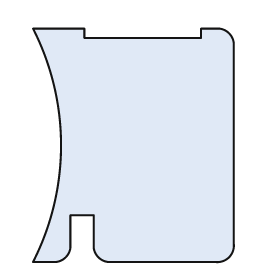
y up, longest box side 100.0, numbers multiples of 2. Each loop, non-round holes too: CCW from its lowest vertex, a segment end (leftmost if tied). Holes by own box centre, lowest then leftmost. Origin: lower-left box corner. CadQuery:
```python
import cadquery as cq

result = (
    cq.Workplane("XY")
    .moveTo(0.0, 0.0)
    .lineTo(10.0, 0.0)
    .threePointArc((14.0, 2.0), (16.0, 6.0))
    .lineTo(16.0, 20.0)
    .lineTo(26.0, 20.0)
    .lineTo(26.0, 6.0)
    .threePointArc((28.0, 2.0), (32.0, 0.0))
    .lineTo(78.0, 0.0)
    .threePointArc((84.0, 2.0), (86.0, 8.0))
    .lineTo(86.0, 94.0)
    .threePointArc((84.0, 98.0), (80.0, 100.0))
    .lineTo(72.0, 100.0)
    .lineTo(72.0, 96.0)
    .lineTo(22.0, 96.0)
    .lineTo(22.0, 100.0)
    .lineTo(0.0, 100.0)
    .threePointArc((12.0, 50.0), (0.0, 0.0))
    .close()
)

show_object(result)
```